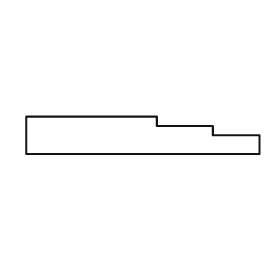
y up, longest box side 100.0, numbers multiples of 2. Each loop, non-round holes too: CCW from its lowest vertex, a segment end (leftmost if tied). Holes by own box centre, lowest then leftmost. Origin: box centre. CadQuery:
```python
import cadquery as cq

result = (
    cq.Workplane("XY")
    .moveTo(-50.0, -8.0)
    .lineTo(50.0, -8.0)
    .lineTo(50.0, 0.0)
    .lineTo(30.0, 0.0)
    .lineTo(30.0, 4.0)
    .lineTo(6.0, 4.0)
    .lineTo(6.0, 8.0)
    .lineTo(-50.0, 8.0)
    .close()
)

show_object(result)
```